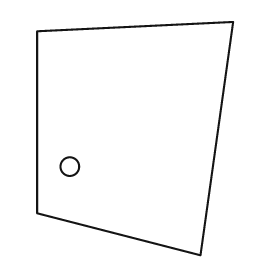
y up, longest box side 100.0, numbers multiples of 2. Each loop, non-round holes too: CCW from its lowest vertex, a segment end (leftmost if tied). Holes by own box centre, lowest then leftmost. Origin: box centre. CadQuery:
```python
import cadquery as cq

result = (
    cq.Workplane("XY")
    .moveTo(28.0, -50.0)
    .lineTo(42.0, 50.0)
    .lineTo(-42.0, 46.0)
    .lineTo(-42.0, -32.0)
    .close()
    .moveTo(-28.0, -12.0)
    .circle(4.0)
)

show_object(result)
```